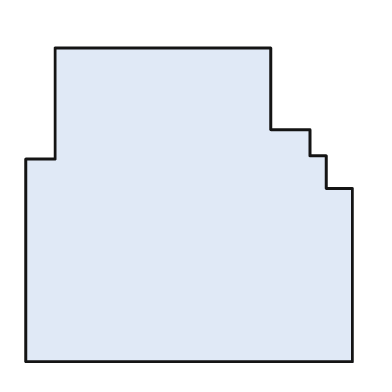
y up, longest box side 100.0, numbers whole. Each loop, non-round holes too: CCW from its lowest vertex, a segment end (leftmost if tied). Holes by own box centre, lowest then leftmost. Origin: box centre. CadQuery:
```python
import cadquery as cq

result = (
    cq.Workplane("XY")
    .moveTo(-50.0, -48.0)
    .lineTo(50.0, -48.0)
    .lineTo(50.0, 5.0)
    .lineTo(42.0, 5.0)
    .lineTo(42.0, 15.0)
    .lineTo(37.0, 15.0)
    .lineTo(37.0, 23.0)
    .lineTo(25.0, 23.0)
    .lineTo(25.0, 48.0)
    .lineTo(-41.0, 48.0)
    .lineTo(-41.0, 14.0)
    .lineTo(-50.0, 14.0)
    .close()
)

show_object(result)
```